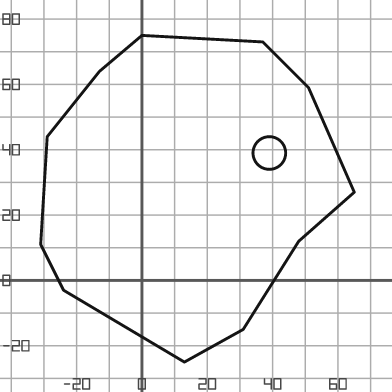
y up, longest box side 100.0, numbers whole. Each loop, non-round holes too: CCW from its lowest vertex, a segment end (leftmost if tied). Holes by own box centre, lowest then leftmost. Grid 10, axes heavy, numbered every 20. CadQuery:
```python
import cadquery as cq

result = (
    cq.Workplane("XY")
    .moveTo(13.0, -25.0)
    .lineTo(31.0, -15.0)
    .lineTo(48.0, 12.0)
    .lineTo(65.0, 27.0)
    .lineTo(51.0, 59.0)
    .lineTo(37.0, 73.0)
    .lineTo(0.0, 75.0)
    .lineTo(-13.0, 64.0)
    .lineTo(-29.0, 44.0)
    .lineTo(-31.0, 11.0)
    .lineTo(-24.0, -3.0)
    .close()
    .moveTo(39.0, 39.0)
    .circle(5.0)
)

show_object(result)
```